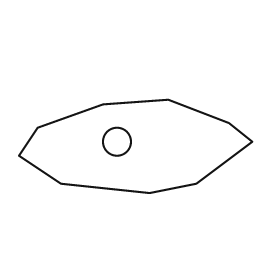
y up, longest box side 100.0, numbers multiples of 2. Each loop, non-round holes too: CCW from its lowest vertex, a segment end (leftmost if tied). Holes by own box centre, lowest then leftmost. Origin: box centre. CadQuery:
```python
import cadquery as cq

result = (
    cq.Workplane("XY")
    .moveTo(6.0, -20.0)
    .lineTo(26.0, -16.0)
    .lineTo(50.0, 2.0)
    .lineTo(40.0, 10.0)
    .lineTo(14.0, 20.0)
    .lineTo(-14.0, 18.0)
    .lineTo(-42.0, 8.0)
    .lineTo(-50.0, -4.0)
    .lineTo(-32.0, -16.0)
    .close()
    .moveTo(-8.0, 2.0)
    .circle(6.0)
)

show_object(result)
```